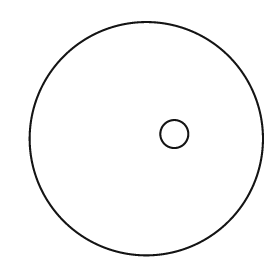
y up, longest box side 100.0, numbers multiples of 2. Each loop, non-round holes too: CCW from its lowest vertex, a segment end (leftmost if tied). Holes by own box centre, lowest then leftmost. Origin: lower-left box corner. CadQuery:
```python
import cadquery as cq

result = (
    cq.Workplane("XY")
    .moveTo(50.0, 50.0)
    .circle(50.0)
    .moveTo(62.0, 52.0)
    .circle(6.0)
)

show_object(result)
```